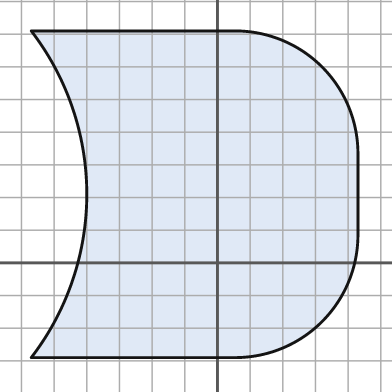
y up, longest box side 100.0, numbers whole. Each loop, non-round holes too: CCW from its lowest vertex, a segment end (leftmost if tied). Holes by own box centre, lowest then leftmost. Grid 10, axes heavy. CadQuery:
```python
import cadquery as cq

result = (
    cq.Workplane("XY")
    .moveTo(-57.0, -29.0)
    .lineTo(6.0, -29.0)
    .threePointArc((32.0, -18.0), (43.0, 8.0))
    .lineTo(43.0, 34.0)
    .threePointArc((32.0, 60.0), (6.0, 71.0))
    .lineTo(-57.0, 71.0)
    .threePointArc((-40.0, 21.0), (-57.0, -29.0))
    .close()
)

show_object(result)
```